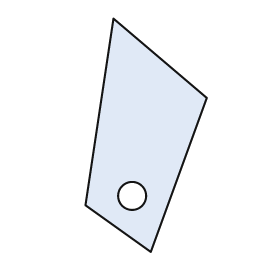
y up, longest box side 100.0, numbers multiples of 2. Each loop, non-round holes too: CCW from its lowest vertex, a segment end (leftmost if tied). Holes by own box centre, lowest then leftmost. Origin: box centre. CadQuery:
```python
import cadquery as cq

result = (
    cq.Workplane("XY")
    .moveTo(2.0, -50.0)
    .lineTo(26.0, 16.0)
    .lineTo(-14.0, 50.0)
    .lineTo(-26.0, -30.0)
    .close()
    .moveTo(-6.0, -26.0)
    .circle(6.0)
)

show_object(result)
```